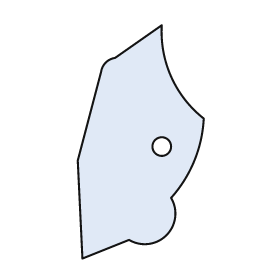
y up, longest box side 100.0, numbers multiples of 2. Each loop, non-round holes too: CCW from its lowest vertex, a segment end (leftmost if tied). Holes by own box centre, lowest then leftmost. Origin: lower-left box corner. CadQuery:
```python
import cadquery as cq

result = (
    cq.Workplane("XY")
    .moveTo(2.0, 0.0)
    .lineTo(22.0, 8.0)
    .threePointArc((38.0, 10.0), (40.0, 26.0))
    .threePointArc((50.0, 42.0), (54.0, 60.0))
    .threePointArc((40.0, 78.0), (36.0, 100.0))
    .lineTo(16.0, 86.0)
    .threePointArc((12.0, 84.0), (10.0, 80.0))
    .lineTo(0.0, 42.0)
    .close()
    .moveTo(36.0, 48.0)
    .circle(4.0)
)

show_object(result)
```